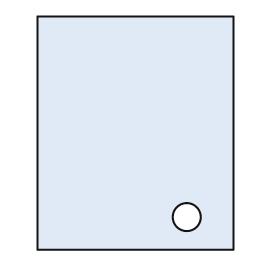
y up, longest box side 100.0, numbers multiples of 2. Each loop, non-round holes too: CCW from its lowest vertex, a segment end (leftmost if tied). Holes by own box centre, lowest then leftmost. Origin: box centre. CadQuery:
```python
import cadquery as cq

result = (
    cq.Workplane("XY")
    .moveTo(-42.0, -50.0)
    .lineTo(42.0, -50.0)
    .lineTo(42.0, 50.0)
    .lineTo(-42.0, 50.0)
    .close()
    .moveTo(22.0, -36.0)
    .circle(6.0)
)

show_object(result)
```